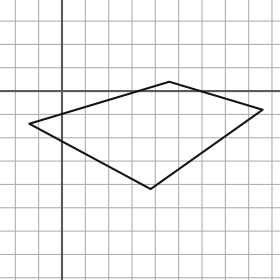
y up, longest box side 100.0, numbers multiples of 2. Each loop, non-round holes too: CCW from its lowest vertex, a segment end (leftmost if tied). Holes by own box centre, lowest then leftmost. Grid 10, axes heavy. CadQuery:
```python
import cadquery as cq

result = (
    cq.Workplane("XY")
    .moveTo(38.0, -42.0)
    .lineTo(86.0, -8.0)
    .lineTo(46.0, 4.0)
    .lineTo(-14.0, -14.0)
    .close()
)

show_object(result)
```